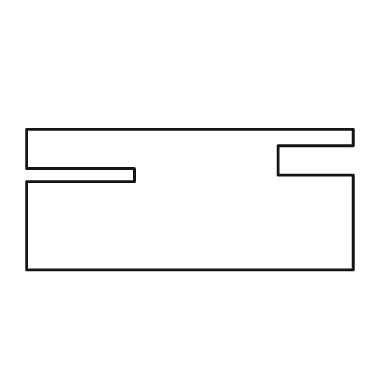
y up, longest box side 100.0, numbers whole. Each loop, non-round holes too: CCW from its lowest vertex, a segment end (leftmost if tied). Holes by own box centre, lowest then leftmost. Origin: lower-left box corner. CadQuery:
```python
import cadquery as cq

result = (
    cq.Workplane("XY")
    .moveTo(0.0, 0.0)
    .lineTo(100.0, 0.0)
    .lineTo(100.0, 29.0)
    .lineTo(77.0, 29.0)
    .lineTo(77.0, 38.0)
    .lineTo(100.0, 38.0)
    .lineTo(100.0, 43.0)
    .lineTo(0.0, 43.0)
    .lineTo(0.0, 31.0)
    .lineTo(33.0, 31.0)
    .lineTo(33.0, 27.0)
    .lineTo(0.0, 27.0)
    .close()
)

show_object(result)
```